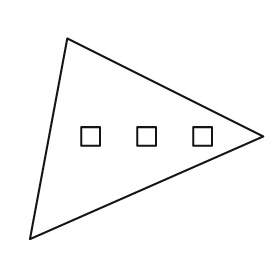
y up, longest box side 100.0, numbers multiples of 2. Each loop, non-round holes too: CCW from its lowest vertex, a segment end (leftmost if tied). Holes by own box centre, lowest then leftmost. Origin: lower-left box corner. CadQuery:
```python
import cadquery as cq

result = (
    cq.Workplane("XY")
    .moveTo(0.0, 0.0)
    .lineTo(100.0, 44.0)
    .lineTo(16.0, 86.0)
    .close()
    .moveTo(22.0, 40.0)
    .lineTo(30.0, 40.0)
    .lineTo(30.0, 48.0)
    .lineTo(22.0, 48.0)
    .close()
    .moveTo(46.0, 40.0)
    .lineTo(54.0, 40.0)
    .lineTo(54.0, 48.0)
    .lineTo(46.0, 48.0)
    .close()
    .moveTo(70.0, 40.0)
    .lineTo(78.0, 40.0)
    .lineTo(78.0, 48.0)
    .lineTo(70.0, 48.0)
    .close()
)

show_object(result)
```